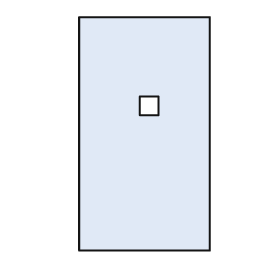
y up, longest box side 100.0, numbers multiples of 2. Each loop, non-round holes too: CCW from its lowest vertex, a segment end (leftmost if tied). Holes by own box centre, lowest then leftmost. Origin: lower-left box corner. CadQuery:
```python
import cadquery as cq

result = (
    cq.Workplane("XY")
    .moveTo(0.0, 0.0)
    .lineTo(56.0, 0.0)
    .lineTo(56.0, 100.0)
    .lineTo(0.0, 100.0)
    .close()
    .moveTo(26.0, 58.0)
    .lineTo(34.0, 58.0)
    .lineTo(34.0, 66.0)
    .lineTo(26.0, 66.0)
    .close()
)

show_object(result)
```